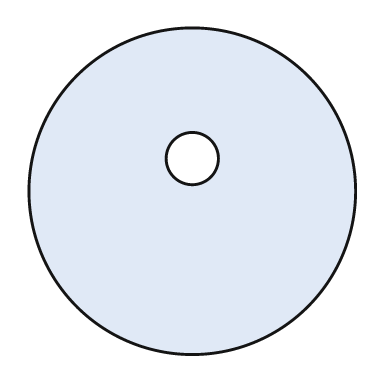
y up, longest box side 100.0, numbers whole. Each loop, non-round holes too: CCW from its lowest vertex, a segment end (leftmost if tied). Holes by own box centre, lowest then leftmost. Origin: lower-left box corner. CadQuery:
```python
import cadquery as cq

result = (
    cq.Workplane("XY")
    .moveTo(50.0, 50.0)
    .circle(50.0)
    .moveTo(50.0, 60.0)
    .circle(8.0)
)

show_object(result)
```